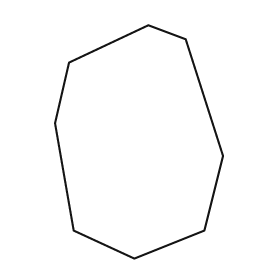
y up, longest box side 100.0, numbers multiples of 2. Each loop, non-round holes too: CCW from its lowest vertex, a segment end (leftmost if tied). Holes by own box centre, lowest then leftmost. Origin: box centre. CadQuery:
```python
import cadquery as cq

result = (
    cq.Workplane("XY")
    .moveTo(-2.0, -50.0)
    .lineTo(28.0, -38.0)
    .lineTo(36.0, -6.0)
    .lineTo(20.0, 44.0)
    .lineTo(4.0, 50.0)
    .lineTo(-30.0, 34.0)
    .lineTo(-36.0, 8.0)
    .lineTo(-28.0, -38.0)
    .close()
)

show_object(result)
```